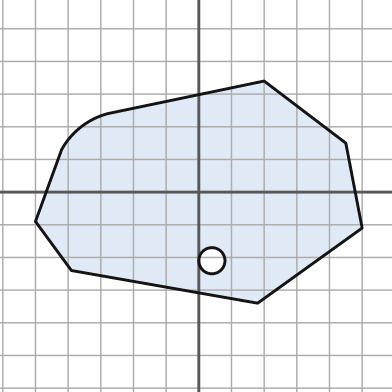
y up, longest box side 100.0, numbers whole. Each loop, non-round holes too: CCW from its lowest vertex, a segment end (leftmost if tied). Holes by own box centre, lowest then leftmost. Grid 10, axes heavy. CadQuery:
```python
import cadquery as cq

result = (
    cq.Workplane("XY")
    .moveTo(18.0, -34.0)
    .lineTo(50.0, -11.0)
    .lineTo(45.0, 15.0)
    .lineTo(20.0, 34.0)
    .lineTo(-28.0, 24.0)
    .threePointArc((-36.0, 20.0), (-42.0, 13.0))
    .lineTo(-50.0, -9.0)
    .lineTo(-39.0, -24.0)
    .close()
    .moveTo(4.0, -21.0)
    .circle(4.0)
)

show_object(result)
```